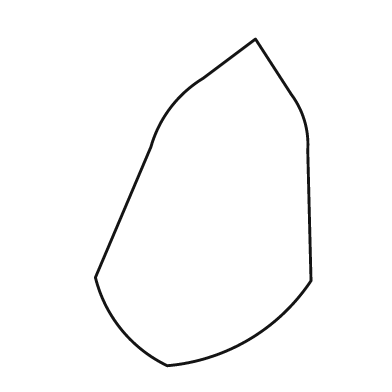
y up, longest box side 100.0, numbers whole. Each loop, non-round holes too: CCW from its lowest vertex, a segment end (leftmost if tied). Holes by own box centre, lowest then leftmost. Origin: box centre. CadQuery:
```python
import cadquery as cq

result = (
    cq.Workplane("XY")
    .moveTo(-11.0, -50.0)
    .threePointArc((14.0, -42.0), (33.0, -24.0))
    .lineTo(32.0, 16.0)
    .threePointArc((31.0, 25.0), (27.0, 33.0))
    .lineTo(16.0, 50.0)
    .lineTo(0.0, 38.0)
    .threePointArc((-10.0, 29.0), (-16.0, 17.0))
    .lineTo(-33.0, -23.0)
    .threePointArc((-25.0, -39.0), (-11.0, -50.0))
    .close()
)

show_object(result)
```